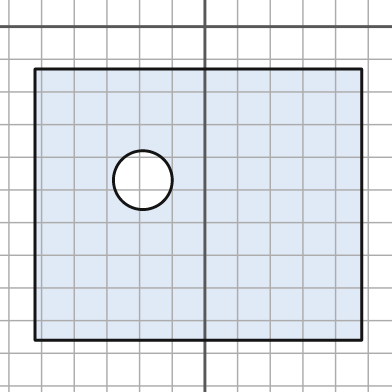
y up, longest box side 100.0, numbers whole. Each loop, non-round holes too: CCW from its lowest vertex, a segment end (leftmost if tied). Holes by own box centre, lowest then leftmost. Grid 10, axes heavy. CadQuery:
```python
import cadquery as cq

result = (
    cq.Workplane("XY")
    .moveTo(-52.0, -96.0)
    .lineTo(48.0, -96.0)
    .lineTo(48.0, -13.0)
    .lineTo(-52.0, -13.0)
    .close()
    .moveTo(-19.0, -47.0)
    .circle(9.0)
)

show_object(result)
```